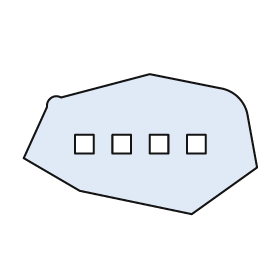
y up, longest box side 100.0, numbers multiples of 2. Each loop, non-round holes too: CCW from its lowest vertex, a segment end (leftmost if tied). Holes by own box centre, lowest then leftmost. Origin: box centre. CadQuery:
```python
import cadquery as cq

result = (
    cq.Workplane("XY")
    .moveTo(22.0, -30.0)
    .lineTo(50.0, -10.0)
    .lineTo(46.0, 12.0)
    .threePointArc((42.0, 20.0), (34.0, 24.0))
    .lineTo(4.0, 30.0)
    .lineTo(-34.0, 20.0)
    .threePointArc((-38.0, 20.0), (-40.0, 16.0))
    .lineTo(-50.0, -6.0)
    .lineTo(-26.0, -20.0)
    .close()
    .moveTo(-28.0, -4.0)
    .lineTo(-20.0, -4.0)
    .lineTo(-20.0, 4.0)
    .lineTo(-28.0, 4.0)
    .close()
    .moveTo(-12.0, -4.0)
    .lineTo(-4.0, -4.0)
    .lineTo(-4.0, 4.0)
    .lineTo(-12.0, 4.0)
    .close()
    .moveTo(4.0, -4.0)
    .lineTo(12.0, -4.0)
    .lineTo(12.0, 4.0)
    .lineTo(4.0, 4.0)
    .close()
    .moveTo(20.0, -4.0)
    .lineTo(28.0, -4.0)
    .lineTo(28.0, 4.0)
    .lineTo(20.0, 4.0)
    .close()
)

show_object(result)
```